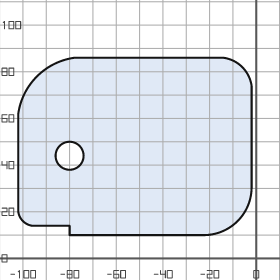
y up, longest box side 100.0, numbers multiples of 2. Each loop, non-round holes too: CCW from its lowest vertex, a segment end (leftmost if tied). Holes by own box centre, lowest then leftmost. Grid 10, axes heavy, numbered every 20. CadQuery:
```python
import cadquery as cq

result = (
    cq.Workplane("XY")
    .moveTo(-80.0, 10.0)
    .lineTo(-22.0, 10.0)
    .threePointArc((-8.0, 16.0), (-2.0, 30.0))
    .lineTo(-2.0, 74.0)
    .threePointArc((-6.0, 82.0), (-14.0, 86.0))
    .lineTo(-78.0, 86.0)
    .threePointArc((-94.0, 78.0), (-102.0, 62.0))
    .lineTo(-102.0, 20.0)
    .threePointArc((-100.0, 16.0), (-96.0, 14.0))
    .lineTo(-80.0, 14.0)
    .close()
    .moveTo(-80.0, 44.0)
    .circle(6.0)
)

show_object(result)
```